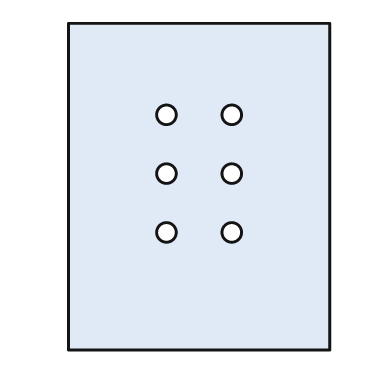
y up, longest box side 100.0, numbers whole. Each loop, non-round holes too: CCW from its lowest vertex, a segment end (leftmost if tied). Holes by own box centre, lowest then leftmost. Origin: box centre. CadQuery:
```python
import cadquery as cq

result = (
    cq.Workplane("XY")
    .moveTo(-40.0, -50.0)
    .lineTo(40.0, -50.0)
    .lineTo(40.0, 50.0)
    .lineTo(-40.0, 50.0)
    .close()
    .moveTo(-10.0, -14.0)
    .circle(3.0)
    .moveTo(10.0, -14.0)
    .circle(3.0)
    .moveTo(-10.0, 4.0)
    .circle(3.0)
    .moveTo(10.0, 4.0)
    .circle(3.0)
    .moveTo(-10.0, 22.0)
    .circle(3.0)
    .moveTo(10.0, 22.0)
    .circle(3.0)
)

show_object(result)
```